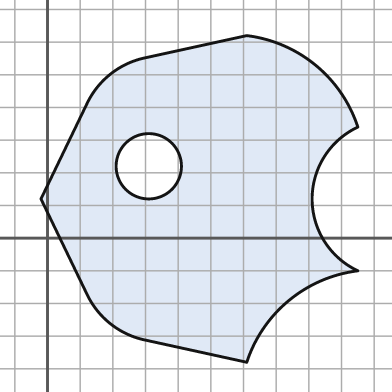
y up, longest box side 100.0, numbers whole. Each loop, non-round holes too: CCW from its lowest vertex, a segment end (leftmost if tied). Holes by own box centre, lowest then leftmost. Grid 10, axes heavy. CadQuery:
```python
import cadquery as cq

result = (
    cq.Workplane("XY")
    .moveTo(61.0, -38.0)
    .threePointArc((74.0, -19.0), (95.0, -10.0))
    .threePointArc((81.0, 12.0), (95.0, 34.0))
    .threePointArc((82.0, 53.0), (61.0, 62.0))
    .lineTo(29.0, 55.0)
    .threePointArc((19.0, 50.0), (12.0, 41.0))
    .lineTo(-2.0, 12.0)
    .lineTo(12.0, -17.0)
    .threePointArc((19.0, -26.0), (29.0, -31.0))
    .close()
    .moveTo(31.0, 22.0)
    .circle(10.0)
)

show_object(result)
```